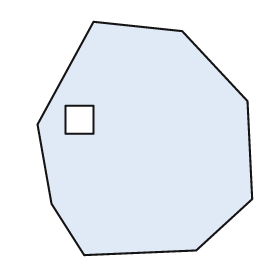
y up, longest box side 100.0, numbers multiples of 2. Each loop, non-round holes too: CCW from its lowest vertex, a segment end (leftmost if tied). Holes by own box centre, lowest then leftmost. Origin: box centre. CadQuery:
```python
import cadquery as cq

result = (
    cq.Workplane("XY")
    .moveTo(-26.0, -50.0)
    .lineTo(22.0, -48.0)
    .lineTo(46.0, -26.0)
    .lineTo(44.0, 16.0)
    .lineTo(16.0, 46.0)
    .lineTo(-22.0, 50.0)
    .lineTo(-46.0, 6.0)
    .lineTo(-40.0, -28.0)
    .close()
    .moveTo(-34.0, 2.0)
    .lineTo(-22.0, 2.0)
    .lineTo(-22.0, 14.0)
    .lineTo(-34.0, 14.0)
    .close()
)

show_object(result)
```